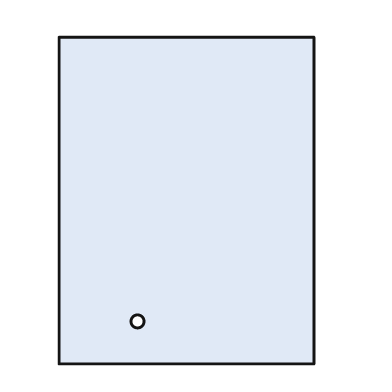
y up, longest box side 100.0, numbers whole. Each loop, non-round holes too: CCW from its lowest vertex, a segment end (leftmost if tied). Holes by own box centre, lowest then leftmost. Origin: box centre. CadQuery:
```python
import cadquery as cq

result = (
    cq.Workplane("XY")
    .moveTo(-39.0, -50.0)
    .lineTo(39.0, -50.0)
    .lineTo(39.0, 50.0)
    .lineTo(-39.0, 50.0)
    .close()
    .moveTo(-15.0, -37.0)
    .circle(2.0)
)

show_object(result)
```